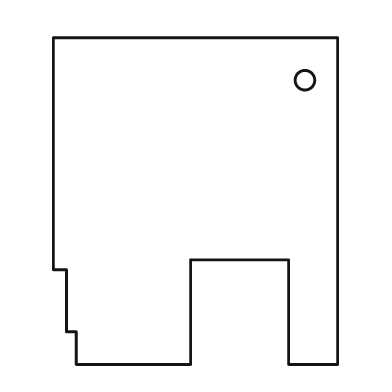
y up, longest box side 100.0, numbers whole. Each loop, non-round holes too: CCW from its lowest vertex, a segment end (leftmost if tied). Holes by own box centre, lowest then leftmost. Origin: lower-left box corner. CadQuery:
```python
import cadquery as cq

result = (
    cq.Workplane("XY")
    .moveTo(7.0, 0.0)
    .lineTo(42.0, 0.0)
    .lineTo(42.0, 32.0)
    .lineTo(72.0, 32.0)
    .lineTo(72.0, 0.0)
    .lineTo(87.0, 0.0)
    .lineTo(87.0, 100.0)
    .lineTo(0.0, 100.0)
    .lineTo(0.0, 29.0)
    .lineTo(4.0, 29.0)
    .lineTo(4.0, 10.0)
    .lineTo(7.0, 10.0)
    .close()
    .moveTo(77.0, 87.0)
    .circle(3.0)
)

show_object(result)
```